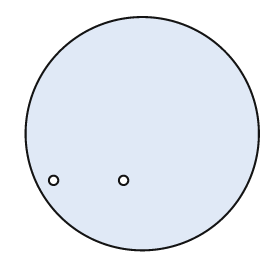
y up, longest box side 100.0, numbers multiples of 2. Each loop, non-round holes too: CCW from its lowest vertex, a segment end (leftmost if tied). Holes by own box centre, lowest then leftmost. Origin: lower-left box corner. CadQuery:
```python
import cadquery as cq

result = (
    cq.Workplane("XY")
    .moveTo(50.0, 50.0)
    .circle(50.0)
    .moveTo(12.0, 30.0)
    .circle(2.0)
    .moveTo(42.0, 30.0)
    .circle(2.0)
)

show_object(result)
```